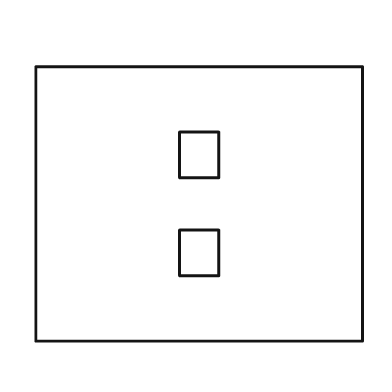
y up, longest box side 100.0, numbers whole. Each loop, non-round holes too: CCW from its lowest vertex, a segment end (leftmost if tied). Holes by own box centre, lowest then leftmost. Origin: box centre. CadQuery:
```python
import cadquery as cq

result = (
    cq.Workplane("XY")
    .moveTo(-50.0, -42.0)
    .lineTo(50.0, -42.0)
    .lineTo(50.0, 42.0)
    .lineTo(-50.0, 42.0)
    .close()
    .moveTo(-6.0, -22.0)
    .lineTo(6.0, -22.0)
    .lineTo(6.0, -8.0)
    .lineTo(-6.0, -8.0)
    .close()
    .moveTo(-6.0, 8.0)
    .lineTo(6.0, 8.0)
    .lineTo(6.0, 22.0)
    .lineTo(-6.0, 22.0)
    .close()
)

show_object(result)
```